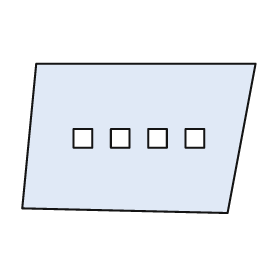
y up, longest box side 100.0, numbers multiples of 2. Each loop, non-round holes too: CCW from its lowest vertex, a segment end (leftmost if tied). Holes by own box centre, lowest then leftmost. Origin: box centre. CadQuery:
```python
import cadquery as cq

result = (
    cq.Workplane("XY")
    .moveTo(38.0, -32.0)
    .lineTo(50.0, 32.0)
    .lineTo(-44.0, 32.0)
    .lineTo(-50.0, -30.0)
    .close()
    .moveTo(-28.0, -4.0)
    .lineTo(-20.0, -4.0)
    .lineTo(-20.0, 4.0)
    .lineTo(-28.0, 4.0)
    .close()
    .moveTo(-12.0, -4.0)
    .lineTo(-4.0, -4.0)
    .lineTo(-4.0, 4.0)
    .lineTo(-12.0, 4.0)
    .close()
    .moveTo(4.0, -4.0)
    .lineTo(12.0, -4.0)
    .lineTo(12.0, 4.0)
    .lineTo(4.0, 4.0)
    .close()
    .moveTo(20.0, -4.0)
    .lineTo(28.0, -4.0)
    .lineTo(28.0, 4.0)
    .lineTo(20.0, 4.0)
    .close()
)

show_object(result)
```